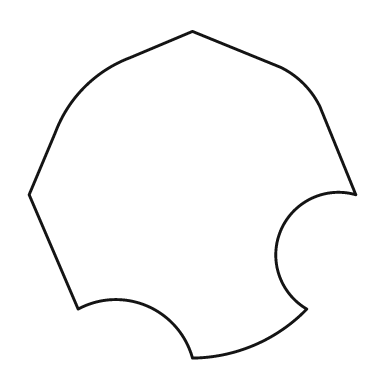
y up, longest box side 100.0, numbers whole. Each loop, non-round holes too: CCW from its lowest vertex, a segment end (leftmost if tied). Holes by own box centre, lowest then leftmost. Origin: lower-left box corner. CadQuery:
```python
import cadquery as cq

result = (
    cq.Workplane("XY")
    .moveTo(50.0, 0.0)
    .threePointArc((69.0, 4.0), (85.0, 15.0))
    .threePointArc((77.0, 39.0), (100.0, 50.0))
    .lineTo(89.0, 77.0)
    .threePointArc((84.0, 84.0), (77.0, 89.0))
    .lineTo(50.0, 100.0)
    .lineTo(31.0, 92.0)
    .threePointArc((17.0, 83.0), (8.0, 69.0))
    .lineTo(0.0, 50.0)
    .lineTo(15.0, 15.0)
    .threePointArc((36.0, 16.0), (50.0, 0.0))
    .close()
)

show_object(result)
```